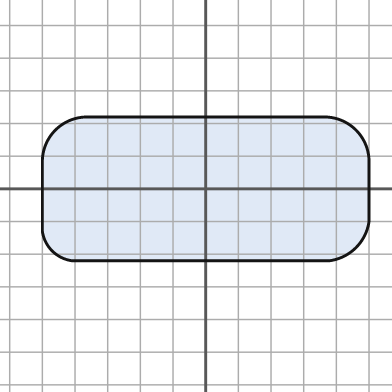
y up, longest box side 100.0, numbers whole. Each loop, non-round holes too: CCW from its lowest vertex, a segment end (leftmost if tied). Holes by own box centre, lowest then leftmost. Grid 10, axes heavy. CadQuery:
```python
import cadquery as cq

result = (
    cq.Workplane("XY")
    .moveTo(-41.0, -22.0)
    .lineTo(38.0, -22.0)
    .threePointArc((46.0, -18.0), (50.0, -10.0))
    .lineTo(50.0, 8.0)
    .threePointArc((46.0, 18.0), (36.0, 22.0))
    .lineTo(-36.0, 22.0)
    .threePointArc((-46.0, 18.0), (-50.0, 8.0))
    .lineTo(-50.0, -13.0)
    .threePointArc((-47.0, -19.0), (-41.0, -22.0))
    .close()
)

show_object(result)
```